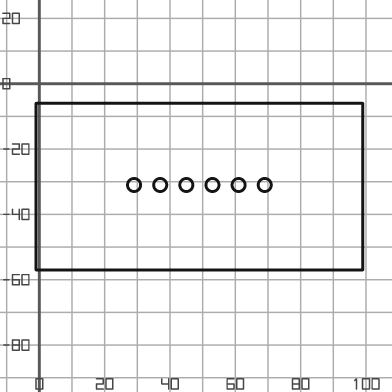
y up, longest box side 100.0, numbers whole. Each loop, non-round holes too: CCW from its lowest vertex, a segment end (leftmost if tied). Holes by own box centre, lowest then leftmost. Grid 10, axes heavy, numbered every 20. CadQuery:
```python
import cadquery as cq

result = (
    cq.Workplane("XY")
    .moveTo(-1.0, -57.0)
    .lineTo(99.0, -57.0)
    .lineTo(99.0, -6.0)
    .lineTo(-1.0, -6.0)
    .close()
    .moveTo(29.0, -31.0)
    .circle(2.0)
    .moveTo(37.0, -31.0)
    .circle(2.0)
    .moveTo(45.0, -31.0)
    .circle(2.0)
    .moveTo(53.0, -31.0)
    .circle(2.0)
    .moveTo(61.0, -31.0)
    .circle(2.0)
    .moveTo(69.0, -31.0)
    .circle(2.0)
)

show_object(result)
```